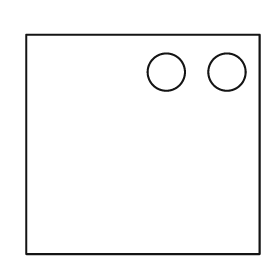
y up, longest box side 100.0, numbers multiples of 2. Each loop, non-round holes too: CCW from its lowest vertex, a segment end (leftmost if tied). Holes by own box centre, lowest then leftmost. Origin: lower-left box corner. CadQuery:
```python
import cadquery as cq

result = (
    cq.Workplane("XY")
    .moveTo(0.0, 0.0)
    .lineTo(100.0, 0.0)
    .lineTo(100.0, 94.0)
    .lineTo(0.0, 94.0)
    .close()
    .moveTo(60.0, 78.0)
    .circle(8.0)
    .moveTo(86.0, 78.0)
    .circle(8.0)
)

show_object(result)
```